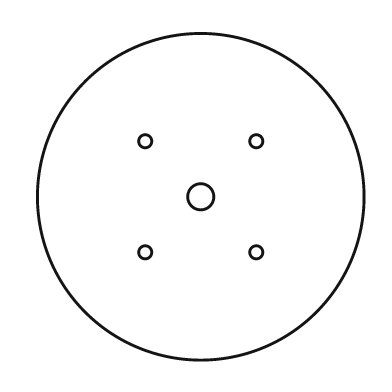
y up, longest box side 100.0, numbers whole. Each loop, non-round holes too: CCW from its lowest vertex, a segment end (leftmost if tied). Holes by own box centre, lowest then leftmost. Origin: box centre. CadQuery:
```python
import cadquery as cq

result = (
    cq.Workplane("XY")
    .moveTo(0.0, 0.0)
    .circle(50.0)
    .moveTo(-17.0, -17.0)
    .circle(2.0)
    .moveTo(17.0, -17.0)
    .circle(2.0)
    .moveTo(0.0, 0.0)
    .circle(4.0)
    .moveTo(-17.0, 17.0)
    .circle(2.0)
    .moveTo(17.0, 17.0)
    .circle(2.0)
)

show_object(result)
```